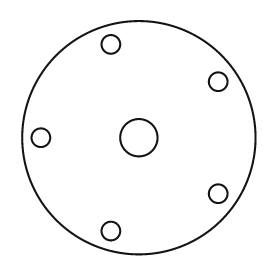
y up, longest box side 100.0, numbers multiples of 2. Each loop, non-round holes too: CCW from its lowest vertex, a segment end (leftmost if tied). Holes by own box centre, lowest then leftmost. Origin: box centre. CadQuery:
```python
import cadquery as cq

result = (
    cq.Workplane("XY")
    .moveTo(0.0, 0.0)
    .circle(50.0)
    .moveTo(-12.0, -40.0)
    .circle(4.0)
    .moveTo(34.0, -24.0)
    .circle(4.0)
    .moveTo(-42.0, 0.0)
    .circle(4.0)
    .moveTo(0.0, 0.0)
    .circle(8.0)
    .moveTo(34.0, 24.0)
    .circle(4.0)
    .moveTo(-12.0, 40.0)
    .circle(4.0)
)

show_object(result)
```